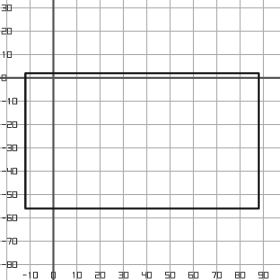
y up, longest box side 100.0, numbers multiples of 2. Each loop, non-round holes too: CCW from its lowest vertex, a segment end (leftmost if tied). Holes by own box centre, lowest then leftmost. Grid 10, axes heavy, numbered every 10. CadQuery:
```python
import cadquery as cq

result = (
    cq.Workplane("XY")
    .moveTo(-12.0, -56.0)
    .lineTo(88.0, -56.0)
    .lineTo(88.0, 2.0)
    .lineTo(-12.0, 2.0)
    .close()
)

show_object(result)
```